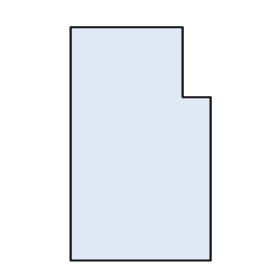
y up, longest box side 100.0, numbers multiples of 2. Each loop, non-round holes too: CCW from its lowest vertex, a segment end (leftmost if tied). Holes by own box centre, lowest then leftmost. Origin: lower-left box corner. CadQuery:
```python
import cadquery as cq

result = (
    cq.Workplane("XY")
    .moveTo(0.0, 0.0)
    .lineTo(60.0, 0.0)
    .lineTo(60.0, 70.0)
    .lineTo(48.0, 70.0)
    .lineTo(48.0, 100.0)
    .lineTo(0.0, 100.0)
    .close()
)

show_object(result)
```